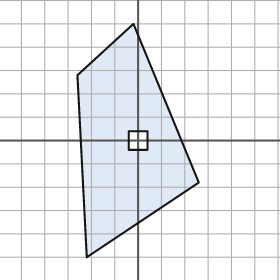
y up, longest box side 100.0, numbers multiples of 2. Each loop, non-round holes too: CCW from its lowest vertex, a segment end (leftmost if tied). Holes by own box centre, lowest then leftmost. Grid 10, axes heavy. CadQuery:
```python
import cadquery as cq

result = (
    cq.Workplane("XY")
    .moveTo(-22.0, -50.0)
    .lineTo(26.0, -18.0)
    .lineTo(-2.0, 50.0)
    .lineTo(-26.0, 28.0)
    .close()
    .moveTo(-4.0, -4.0)
    .lineTo(4.0, -4.0)
    .lineTo(4.0, 4.0)
    .lineTo(-4.0, 4.0)
    .close()
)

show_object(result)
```